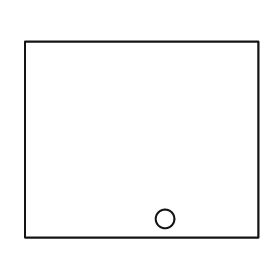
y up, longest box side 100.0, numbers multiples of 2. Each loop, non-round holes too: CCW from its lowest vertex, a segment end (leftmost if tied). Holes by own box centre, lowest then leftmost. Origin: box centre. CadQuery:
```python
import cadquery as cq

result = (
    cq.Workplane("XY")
    .moveTo(-50.0, -42.0)
    .lineTo(50.0, -42.0)
    .lineTo(50.0, 42.0)
    .lineTo(-50.0, 42.0)
    .close()
    .moveTo(10.0, -34.0)
    .circle(4.0)
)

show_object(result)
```